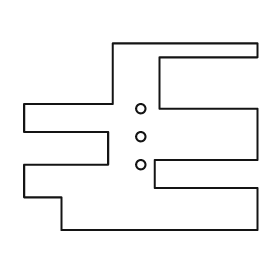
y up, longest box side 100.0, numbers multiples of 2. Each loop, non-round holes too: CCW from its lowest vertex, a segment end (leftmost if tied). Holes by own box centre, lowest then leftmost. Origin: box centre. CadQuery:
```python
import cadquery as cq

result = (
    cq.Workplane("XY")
    .moveTo(-34.0, -40.0)
    .lineTo(50.0, -40.0)
    .lineTo(50.0, -22.0)
    .lineTo(6.0, -22.0)
    .lineTo(6.0, -10.0)
    .lineTo(50.0, -10.0)
    .lineTo(50.0, 12.0)
    .lineTo(8.0, 12.0)
    .lineTo(8.0, 34.0)
    .lineTo(50.0, 34.0)
    .lineTo(50.0, 40.0)
    .lineTo(-12.0, 40.0)
    .lineTo(-12.0, 14.0)
    .lineTo(-50.0, 14.0)
    .lineTo(-50.0, 2.0)
    .lineTo(-14.0, 2.0)
    .lineTo(-14.0, -12.0)
    .lineTo(-50.0, -12.0)
    .lineTo(-50.0, -26.0)
    .lineTo(-34.0, -26.0)
    .close()
    .moveTo(0.0, -12.0)
    .circle(2.0)
    .moveTo(0.0, 0.0)
    .circle(2.0)
    .moveTo(0.0, 12.0)
    .circle(2.0)
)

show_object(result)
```